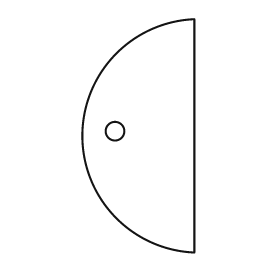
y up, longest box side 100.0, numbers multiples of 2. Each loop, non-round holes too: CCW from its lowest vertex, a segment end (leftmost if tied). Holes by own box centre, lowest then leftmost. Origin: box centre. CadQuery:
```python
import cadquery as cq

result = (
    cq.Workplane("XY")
    .moveTo(24.0, -50.0)
    .lineTo(24.0, 50.0)
    .threePointArc((-24.0, 0.0), (24.0, -50.0))
    .close()
    .moveTo(-10.0, 2.0)
    .circle(4.0)
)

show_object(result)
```